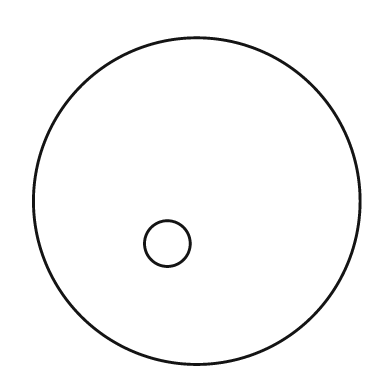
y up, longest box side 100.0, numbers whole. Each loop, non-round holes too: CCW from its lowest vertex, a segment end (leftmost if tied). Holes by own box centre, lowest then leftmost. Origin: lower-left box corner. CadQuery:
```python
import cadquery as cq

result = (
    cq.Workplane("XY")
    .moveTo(50.0, 50.0)
    .circle(50.0)
    .moveTo(41.0, 37.0)
    .circle(7.0)
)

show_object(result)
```